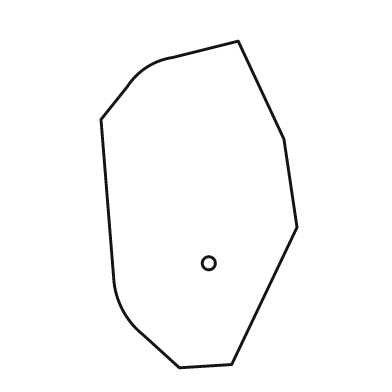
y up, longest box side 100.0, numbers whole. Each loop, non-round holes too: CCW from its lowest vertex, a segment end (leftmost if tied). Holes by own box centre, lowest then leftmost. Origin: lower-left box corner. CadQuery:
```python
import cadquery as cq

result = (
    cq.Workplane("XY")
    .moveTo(24.0, 0.0)
    .lineTo(40.0, 1.0)
    .lineTo(60.0, 43.0)
    .lineTo(56.0, 70.0)
    .lineTo(42.0, 100.0)
    .lineTo(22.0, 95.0)
    .threePointArc((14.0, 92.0), (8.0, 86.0))
    .lineTo(0.0, 76.0)
    .lineTo(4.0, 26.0)
    .threePointArc((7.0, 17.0), (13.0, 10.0))
    .close()
    .moveTo(33.0, 32.0)
    .circle(2.0)
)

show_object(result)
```